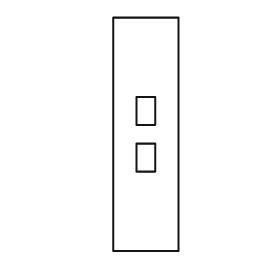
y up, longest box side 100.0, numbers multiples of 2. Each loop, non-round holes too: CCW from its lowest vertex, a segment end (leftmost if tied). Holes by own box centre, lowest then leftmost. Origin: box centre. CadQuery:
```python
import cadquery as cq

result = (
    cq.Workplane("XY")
    .moveTo(-14.0, -50.0)
    .lineTo(14.0, -50.0)
    .lineTo(14.0, 50.0)
    .lineTo(-14.0, 50.0)
    .close()
    .moveTo(-4.0, -16.0)
    .lineTo(4.0, -16.0)
    .lineTo(4.0, -4.0)
    .lineTo(-4.0, -4.0)
    .close()
    .moveTo(-4.0, 4.0)
    .lineTo(4.0, 4.0)
    .lineTo(4.0, 16.0)
    .lineTo(-4.0, 16.0)
    .close()
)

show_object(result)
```